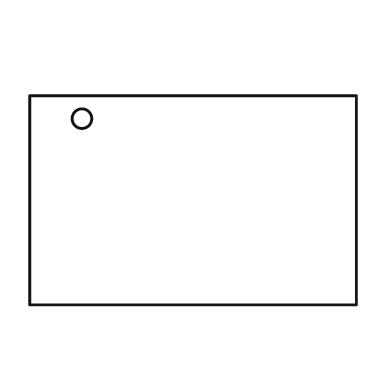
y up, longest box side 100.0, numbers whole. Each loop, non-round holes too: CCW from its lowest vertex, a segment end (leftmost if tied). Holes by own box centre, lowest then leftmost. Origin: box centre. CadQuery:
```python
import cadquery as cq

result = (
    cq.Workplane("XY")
    .moveTo(-50.0, -32.0)
    .lineTo(50.0, -32.0)
    .lineTo(50.0, 32.0)
    .lineTo(-50.0, 32.0)
    .close()
    .moveTo(-34.0, 25.0)
    .circle(3.0)
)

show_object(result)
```